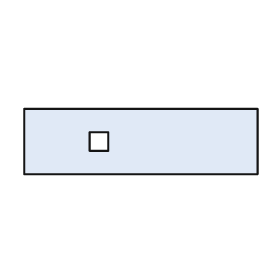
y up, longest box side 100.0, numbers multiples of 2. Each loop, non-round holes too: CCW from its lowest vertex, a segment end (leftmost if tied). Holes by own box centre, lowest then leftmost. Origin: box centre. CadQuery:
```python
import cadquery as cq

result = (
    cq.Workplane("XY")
    .moveTo(-50.0, -14.0)
    .lineTo(50.0, -14.0)
    .lineTo(50.0, 14.0)
    .lineTo(-50.0, 14.0)
    .close()
    .moveTo(-22.0, -4.0)
    .lineTo(-14.0, -4.0)
    .lineTo(-14.0, 4.0)
    .lineTo(-22.0, 4.0)
    .close()
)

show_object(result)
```